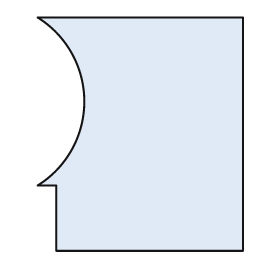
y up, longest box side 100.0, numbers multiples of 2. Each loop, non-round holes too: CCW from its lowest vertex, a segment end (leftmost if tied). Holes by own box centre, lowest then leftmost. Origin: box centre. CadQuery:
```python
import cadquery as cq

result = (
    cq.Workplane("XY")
    .moveTo(-36.0, -50.0)
    .lineTo(44.0, -50.0)
    .lineTo(44.0, 50.0)
    .lineTo(-44.0, 50.0)
    .threePointArc((-24.0, 14.0), (-44.0, -22.0))
    .lineTo(-36.0, -22.0)
    .close()
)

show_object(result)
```